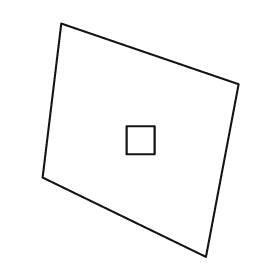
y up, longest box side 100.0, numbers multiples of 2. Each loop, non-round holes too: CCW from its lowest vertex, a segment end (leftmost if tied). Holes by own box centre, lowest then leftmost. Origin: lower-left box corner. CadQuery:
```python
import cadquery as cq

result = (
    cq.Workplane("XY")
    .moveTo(70.0, 0.0)
    .lineTo(84.0, 74.0)
    .lineTo(8.0, 100.0)
    .lineTo(0.0, 34.0)
    .close()
    .moveTo(36.0, 44.0)
    .lineTo(48.0, 44.0)
    .lineTo(48.0, 56.0)
    .lineTo(36.0, 56.0)
    .close()
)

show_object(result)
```